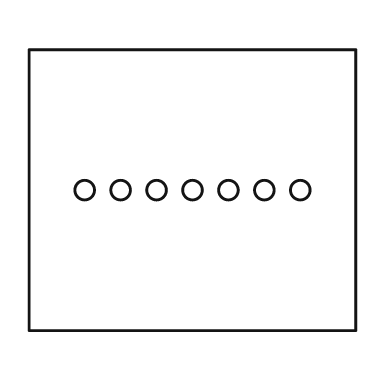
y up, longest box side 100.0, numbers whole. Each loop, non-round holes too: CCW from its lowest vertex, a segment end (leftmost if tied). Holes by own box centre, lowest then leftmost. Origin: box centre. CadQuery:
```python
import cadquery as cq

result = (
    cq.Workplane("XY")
    .moveTo(-50.0, -43.0)
    .lineTo(50.0, -43.0)
    .lineTo(50.0, 43.0)
    .lineTo(-50.0, 43.0)
    .close()
    .moveTo(-33.0, 0.0)
    .circle(3.0)
    .moveTo(-22.0, 0.0)
    .circle(3.0)
    .moveTo(-11.0, 0.0)
    .circle(3.0)
    .moveTo(0.0, 0.0)
    .circle(3.0)
    .moveTo(11.0, 0.0)
    .circle(3.0)
    .moveTo(22.0, 0.0)
    .circle(3.0)
    .moveTo(33.0, 0.0)
    .circle(3.0)
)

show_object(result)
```